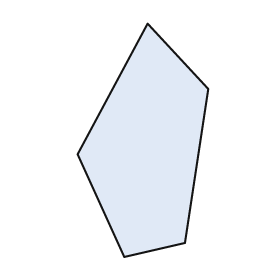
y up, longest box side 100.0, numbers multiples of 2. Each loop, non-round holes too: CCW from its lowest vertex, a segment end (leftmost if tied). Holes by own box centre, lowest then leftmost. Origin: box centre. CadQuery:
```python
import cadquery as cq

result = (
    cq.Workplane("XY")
    .moveTo(-8.0, -50.0)
    .lineTo(18.0, -44.0)
    .lineTo(28.0, 22.0)
    .lineTo(2.0, 50.0)
    .lineTo(-28.0, -6.0)
    .close()
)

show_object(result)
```